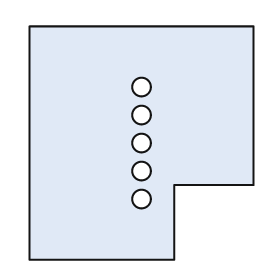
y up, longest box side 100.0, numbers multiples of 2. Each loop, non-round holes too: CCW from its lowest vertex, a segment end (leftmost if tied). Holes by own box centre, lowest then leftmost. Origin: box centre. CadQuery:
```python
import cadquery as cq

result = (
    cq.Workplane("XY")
    .moveTo(-48.0, -50.0)
    .lineTo(14.0, -50.0)
    .lineTo(14.0, -18.0)
    .lineTo(48.0, -18.0)
    .lineTo(48.0, 50.0)
    .lineTo(-48.0, 50.0)
    .close()
    .moveTo(0.0, -24.0)
    .circle(4.0)
    .moveTo(0.0, -12.0)
    .circle(4.0)
    .moveTo(0.0, 0.0)
    .circle(4.0)
    .moveTo(0.0, 12.0)
    .circle(4.0)
    .moveTo(0.0, 24.0)
    .circle(4.0)
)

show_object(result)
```